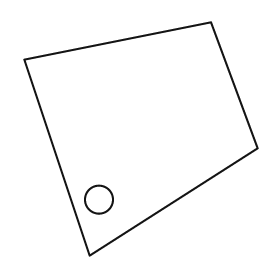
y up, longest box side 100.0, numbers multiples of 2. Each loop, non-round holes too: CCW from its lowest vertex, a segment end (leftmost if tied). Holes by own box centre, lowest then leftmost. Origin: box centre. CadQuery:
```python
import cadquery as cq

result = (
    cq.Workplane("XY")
    .moveTo(-22.0, -50.0)
    .lineTo(50.0, -4.0)
    .lineTo(30.0, 50.0)
    .lineTo(-50.0, 34.0)
    .close()
    .moveTo(-18.0, -26.0)
    .circle(6.0)
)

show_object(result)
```